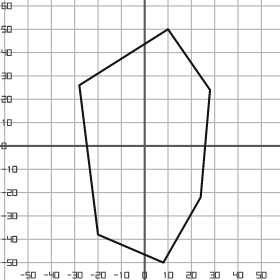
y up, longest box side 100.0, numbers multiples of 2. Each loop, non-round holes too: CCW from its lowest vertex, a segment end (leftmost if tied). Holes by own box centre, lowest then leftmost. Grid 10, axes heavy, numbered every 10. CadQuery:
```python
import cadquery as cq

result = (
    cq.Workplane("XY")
    .moveTo(8.0, -50.0)
    .lineTo(24.0, -22.0)
    .lineTo(28.0, 24.0)
    .lineTo(10.0, 50.0)
    .lineTo(-28.0, 26.0)
    .lineTo(-20.0, -38.0)
    .close()
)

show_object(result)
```